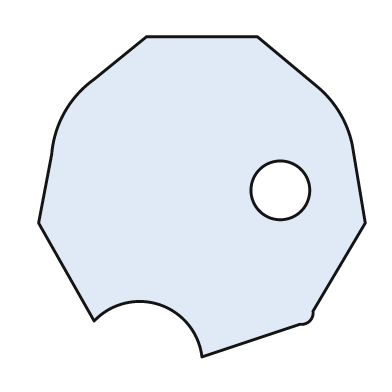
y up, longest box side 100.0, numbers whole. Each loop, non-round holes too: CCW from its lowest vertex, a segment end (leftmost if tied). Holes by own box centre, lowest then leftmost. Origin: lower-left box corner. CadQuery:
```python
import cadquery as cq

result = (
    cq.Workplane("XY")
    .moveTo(50.0, 0.0)
    .lineTo(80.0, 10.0)
    .threePointArc((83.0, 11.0), (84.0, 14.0))
    .lineTo(100.0, 41.0)
    .lineTo(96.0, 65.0)
    .threePointArc((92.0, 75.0), (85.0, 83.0))
    .lineTo(67.0, 98.0)
    .lineTo(33.0, 98.0)
    .lineTo(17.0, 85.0)
    .threePointArc((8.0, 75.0), (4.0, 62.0))
    .lineTo(0.0, 41.0)
    .lineTo(17.0, 11.0)
    .threePointArc((37.0, 16.0), (50.0, 0.0))
    .close()
    .moveTo(74.0, 51.0)
    .circle(9.0)
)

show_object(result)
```